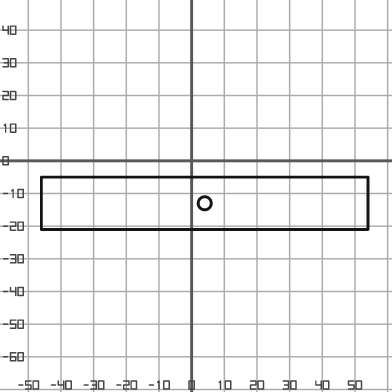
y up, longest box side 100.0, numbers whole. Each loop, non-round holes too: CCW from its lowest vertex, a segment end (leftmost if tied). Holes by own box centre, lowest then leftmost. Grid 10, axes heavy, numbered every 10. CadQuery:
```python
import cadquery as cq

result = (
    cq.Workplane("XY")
    .moveTo(-46.0, -21.0)
    .lineTo(54.0, -21.0)
    .lineTo(54.0, -5.0)
    .lineTo(-46.0, -5.0)
    .close()
    .moveTo(4.0, -13.0)
    .circle(2.0)
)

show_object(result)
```